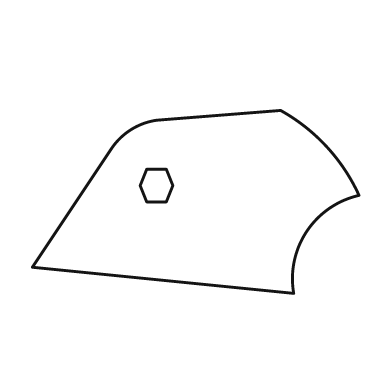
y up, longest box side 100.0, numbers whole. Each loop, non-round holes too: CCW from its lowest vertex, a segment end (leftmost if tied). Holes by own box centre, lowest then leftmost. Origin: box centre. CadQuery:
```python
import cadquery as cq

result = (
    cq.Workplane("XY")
    .moveTo(30.0, -28.0)
    .threePointArc((34.0, -9.0), (50.0, 2.0))
    .threePointArc((40.0, 17.0), (26.0, 28.0))
    .lineTo(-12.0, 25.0)
    .threePointArc((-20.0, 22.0), (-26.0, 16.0))
    .lineTo(-50.0, -20.0)
    .close()
    .moveTo(-15.0, 0.0)
    .lineTo(-9.0, 0.0)
    .lineTo(-7.0, 5.0)
    .lineTo(-9.0, 10.0)
    .lineTo(-15.0, 10.0)
    .lineTo(-17.0, 5.0)
    .close()
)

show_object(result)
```